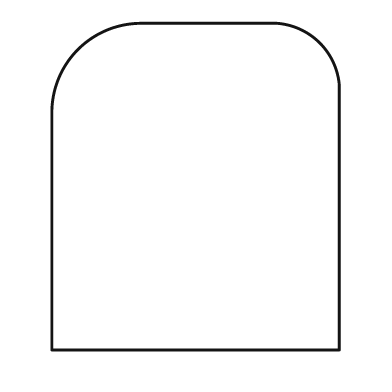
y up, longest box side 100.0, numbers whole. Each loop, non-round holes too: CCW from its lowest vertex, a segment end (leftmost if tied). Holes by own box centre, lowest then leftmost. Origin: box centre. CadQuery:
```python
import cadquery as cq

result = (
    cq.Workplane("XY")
    .moveTo(-44.0, -50.0)
    .lineTo(44.0, -50.0)
    .lineTo(44.0, 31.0)
    .threePointArc((38.0, 44.0), (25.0, 50.0))
    .lineTo(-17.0, 50.0)
    .threePointArc((-36.0, 42.0), (-44.0, 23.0))
    .close()
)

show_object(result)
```